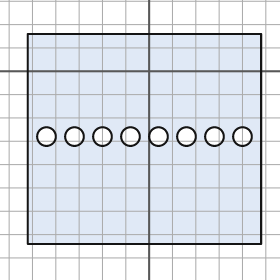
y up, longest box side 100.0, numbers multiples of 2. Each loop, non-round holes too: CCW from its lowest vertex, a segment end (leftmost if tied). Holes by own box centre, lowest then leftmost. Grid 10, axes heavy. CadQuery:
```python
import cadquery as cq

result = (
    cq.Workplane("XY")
    .moveTo(-52.0, -74.0)
    .lineTo(48.0, -74.0)
    .lineTo(48.0, 16.0)
    .lineTo(-52.0, 16.0)
    .close()
    .moveTo(-44.0, -28.0)
    .circle(4.0)
    .moveTo(-32.0, -28.0)
    .circle(4.0)
    .moveTo(-20.0, -28.0)
    .circle(4.0)
    .moveTo(-8.0, -28.0)
    .circle(4.0)
    .moveTo(4.0, -28.0)
    .circle(4.0)
    .moveTo(16.0, -28.0)
    .circle(4.0)
    .moveTo(28.0, -28.0)
    .circle(4.0)
    .moveTo(40.0, -28.0)
    .circle(4.0)
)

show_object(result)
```